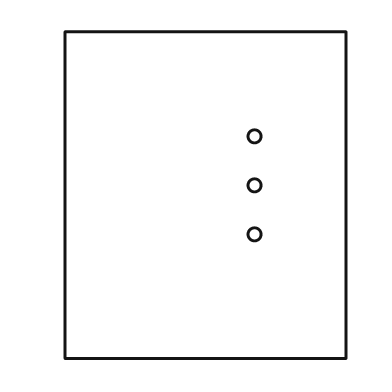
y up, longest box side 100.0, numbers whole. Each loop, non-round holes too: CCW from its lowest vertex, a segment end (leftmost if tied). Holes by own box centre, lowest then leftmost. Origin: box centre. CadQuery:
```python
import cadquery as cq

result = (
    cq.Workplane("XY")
    .moveTo(-43.0, -50.0)
    .lineTo(43.0, -50.0)
    .lineTo(43.0, 50.0)
    .lineTo(-43.0, 50.0)
    .close()
    .moveTo(15.0, -12.0)
    .circle(2.0)
    .moveTo(15.0, 3.0)
    .circle(2.0)
    .moveTo(15.0, 18.0)
    .circle(2.0)
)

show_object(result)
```